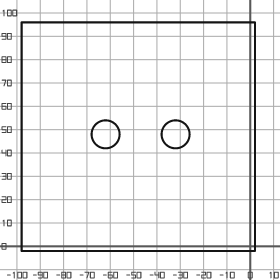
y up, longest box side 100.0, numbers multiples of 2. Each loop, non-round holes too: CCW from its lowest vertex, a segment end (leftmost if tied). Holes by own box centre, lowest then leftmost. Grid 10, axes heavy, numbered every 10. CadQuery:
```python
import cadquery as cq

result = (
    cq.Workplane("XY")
    .moveTo(-98.0, -2.0)
    .lineTo(2.0, -2.0)
    .lineTo(2.0, 96.0)
    .lineTo(-98.0, 96.0)
    .close()
    .moveTo(-62.0, 48.0)
    .circle(6.0)
    .moveTo(-32.0, 48.0)
    .circle(6.0)
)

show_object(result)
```